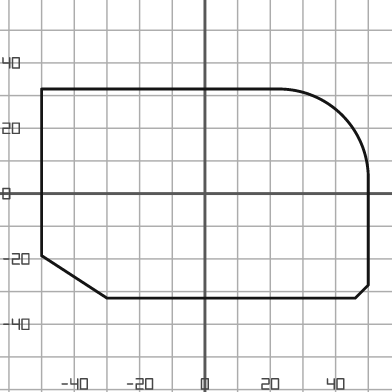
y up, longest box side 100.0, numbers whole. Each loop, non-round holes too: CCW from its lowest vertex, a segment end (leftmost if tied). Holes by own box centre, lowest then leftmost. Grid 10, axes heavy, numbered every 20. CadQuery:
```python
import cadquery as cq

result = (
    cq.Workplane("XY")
    .moveTo(-30.0, -32.0)
    .lineTo(46.0, -32.0)
    .lineTo(50.0, -28.0)
    .lineTo(50.0, 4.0)
    .threePointArc((42.0, 24.0), (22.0, 32.0))
    .lineTo(-50.0, 32.0)
    .lineTo(-50.0, -19.0)
    .close()
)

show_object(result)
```